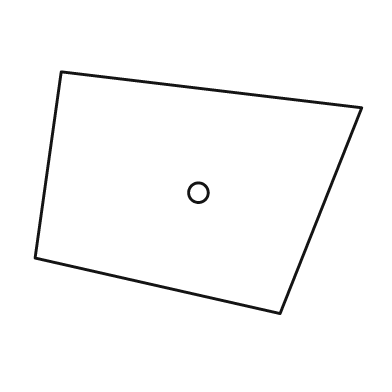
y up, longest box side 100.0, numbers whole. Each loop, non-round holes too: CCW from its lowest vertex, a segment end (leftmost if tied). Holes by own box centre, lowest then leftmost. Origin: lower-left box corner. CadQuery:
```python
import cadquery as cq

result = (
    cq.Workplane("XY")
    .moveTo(75.0, 0.0)
    .lineTo(100.0, 63.0)
    .lineTo(8.0, 74.0)
    .lineTo(0.0, 17.0)
    .close()
    .moveTo(50.0, 37.0)
    .circle(3.0)
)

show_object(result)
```